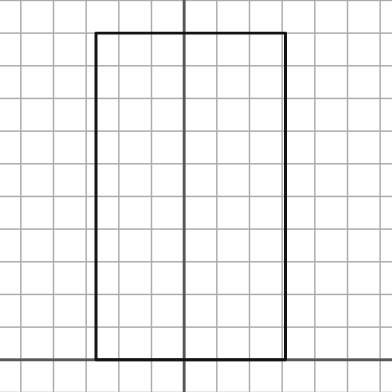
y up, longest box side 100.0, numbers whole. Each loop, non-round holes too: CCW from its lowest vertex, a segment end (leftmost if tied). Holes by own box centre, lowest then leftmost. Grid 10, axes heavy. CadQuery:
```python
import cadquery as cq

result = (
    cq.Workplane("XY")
    .moveTo(-27.0, 0.0)
    .lineTo(31.0, 0.0)
    .lineTo(31.0, 100.0)
    .lineTo(-27.0, 100.0)
    .close()
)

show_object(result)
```